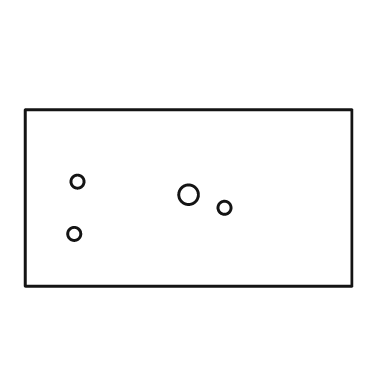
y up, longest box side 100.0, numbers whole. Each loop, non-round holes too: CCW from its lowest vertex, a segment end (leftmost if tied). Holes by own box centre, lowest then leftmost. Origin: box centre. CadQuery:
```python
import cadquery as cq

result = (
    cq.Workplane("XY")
    .moveTo(-50.0, -27.0)
    .lineTo(50.0, -27.0)
    .lineTo(50.0, 27.0)
    .lineTo(-50.0, 27.0)
    .close()
    .moveTo(-35.0, -11.0)
    .circle(2.0)
    .moveTo(11.0, -3.0)
    .circle(2.0)
    .moveTo(0.0, 1.0)
    .circle(3.0)
    .moveTo(-34.0, 5.0)
    .circle(2.0)
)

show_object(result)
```